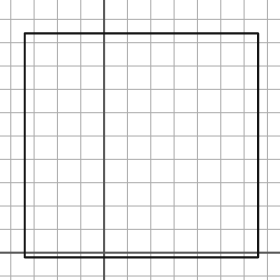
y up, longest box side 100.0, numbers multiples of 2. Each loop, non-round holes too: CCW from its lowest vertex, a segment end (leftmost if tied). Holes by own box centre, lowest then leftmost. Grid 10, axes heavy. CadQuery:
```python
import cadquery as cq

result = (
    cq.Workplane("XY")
    .moveTo(-34.0, -2.0)
    .lineTo(66.0, -2.0)
    .lineTo(66.0, 94.0)
    .lineTo(-34.0, 94.0)
    .close()
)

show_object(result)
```